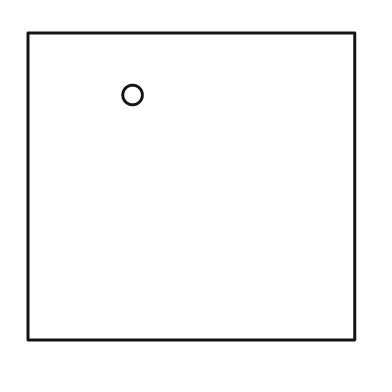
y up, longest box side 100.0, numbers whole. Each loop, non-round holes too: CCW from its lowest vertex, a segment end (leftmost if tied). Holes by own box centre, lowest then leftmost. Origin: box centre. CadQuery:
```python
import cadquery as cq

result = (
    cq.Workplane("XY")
    .moveTo(-50.0, -47.0)
    .lineTo(50.0, -47.0)
    .lineTo(50.0, 47.0)
    .lineTo(-50.0, 47.0)
    .close()
    .moveTo(-18.0, 28.0)
    .circle(3.0)
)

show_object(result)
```